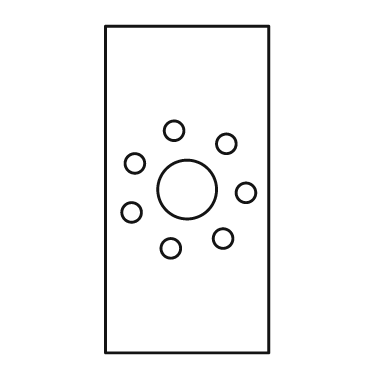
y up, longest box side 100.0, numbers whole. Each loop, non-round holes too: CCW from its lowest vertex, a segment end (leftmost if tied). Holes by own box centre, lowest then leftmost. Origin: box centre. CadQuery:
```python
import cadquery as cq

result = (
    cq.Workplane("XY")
    .moveTo(-25.0, -50.0)
    .lineTo(25.0, -50.0)
    .lineTo(25.0, 50.0)
    .lineTo(-25.0, 50.0)
    .close()
    .moveTo(-5.0, -18.0)
    .circle(3.0)
    .moveTo(11.0, -15.0)
    .circle(3.0)
    .moveTo(-17.0, -7.0)
    .circle(3.0)
    .moveTo(18.0, -1.0)
    .circle(3.0)
    .moveTo(0.0, 0.0)
    .circle(9.0)
    .moveTo(-16.0, 8.0)
    .circle(3.0)
    .moveTo(12.0, 14.0)
    .circle(3.0)
    .moveTo(-4.0, 18.0)
    .circle(3.0)
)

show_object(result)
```